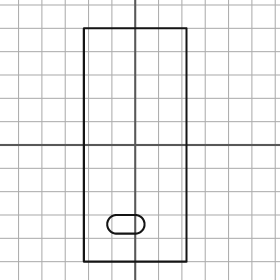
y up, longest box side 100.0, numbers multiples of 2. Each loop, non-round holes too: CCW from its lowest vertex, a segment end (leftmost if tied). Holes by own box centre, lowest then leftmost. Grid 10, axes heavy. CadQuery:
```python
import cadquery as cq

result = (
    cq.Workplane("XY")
    .moveTo(-22.0, -50.0)
    .lineTo(22.0, -50.0)
    .lineTo(22.0, 50.0)
    .lineTo(-22.0, 50.0)
    .close()
    .moveTo(-8.0, -38.0)
    .lineTo(0.0, -38.0)
    .threePointArc((4.0, -34.0), (0.0, -30.0))
    .lineTo(-8.0, -30.0)
    .threePointArc((-12.0, -34.0), (-8.0, -38.0))
    .close()
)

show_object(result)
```